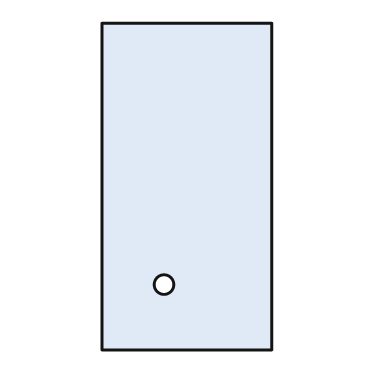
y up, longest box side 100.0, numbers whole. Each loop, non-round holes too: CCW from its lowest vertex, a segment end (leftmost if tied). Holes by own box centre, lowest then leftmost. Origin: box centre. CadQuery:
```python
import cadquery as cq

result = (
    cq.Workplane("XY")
    .moveTo(-26.0, -50.0)
    .lineTo(26.0, -50.0)
    .lineTo(26.0, 50.0)
    .lineTo(-26.0, 50.0)
    .close()
    .moveTo(-7.0, -30.0)
    .circle(3.0)
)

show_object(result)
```